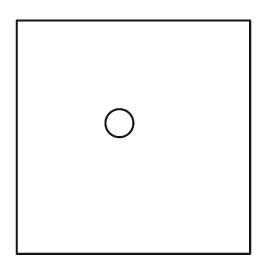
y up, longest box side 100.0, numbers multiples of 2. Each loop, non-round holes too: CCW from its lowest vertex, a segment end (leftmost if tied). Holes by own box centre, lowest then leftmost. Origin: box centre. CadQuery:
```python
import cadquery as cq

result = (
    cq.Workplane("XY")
    .moveTo(-50.0, -50.0)
    .lineTo(50.0, -50.0)
    .lineTo(50.0, 50.0)
    .lineTo(-50.0, 50.0)
    .close()
    .moveTo(-6.0, 6.0)
    .circle(6.0)
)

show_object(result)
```